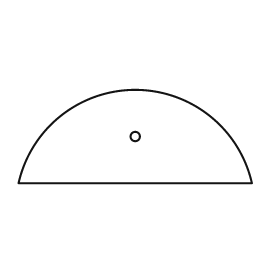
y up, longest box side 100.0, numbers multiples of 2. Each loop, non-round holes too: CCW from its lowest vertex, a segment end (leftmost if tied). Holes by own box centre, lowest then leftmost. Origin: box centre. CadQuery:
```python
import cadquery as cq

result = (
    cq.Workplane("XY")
    .moveTo(-50.0, -20.0)
    .lineTo(50.0, -20.0)
    .threePointArc((0.0, 20.0), (-50.0, -20.0))
    .close()
    .moveTo(0.0, 0.0)
    .circle(2.0)
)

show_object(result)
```